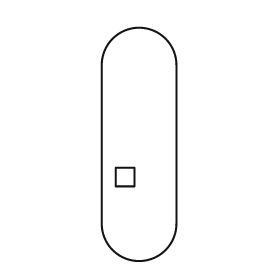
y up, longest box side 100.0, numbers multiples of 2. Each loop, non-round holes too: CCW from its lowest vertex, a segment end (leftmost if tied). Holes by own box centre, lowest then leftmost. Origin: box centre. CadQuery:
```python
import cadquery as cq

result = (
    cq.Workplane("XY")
    .moveTo(-16.0, -34.0)
    .threePointArc((0.0, -50.0), (16.0, -34.0))
    .lineTo(16.0, 34.0)
    .threePointArc((0.0, 50.0), (-16.0, 34.0))
    .close()
    .moveTo(-10.0, -18.0)
    .lineTo(-2.0, -18.0)
    .lineTo(-2.0, -10.0)
    .lineTo(-10.0, -10.0)
    .close()
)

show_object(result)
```